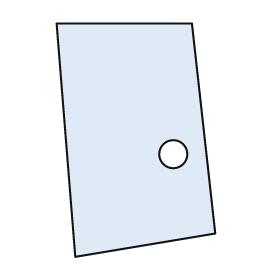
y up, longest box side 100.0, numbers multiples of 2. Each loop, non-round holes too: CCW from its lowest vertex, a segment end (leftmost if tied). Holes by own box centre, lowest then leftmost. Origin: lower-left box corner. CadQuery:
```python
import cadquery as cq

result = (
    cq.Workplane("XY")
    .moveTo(8.0, 0.0)
    .lineTo(68.0, 10.0)
    .lineTo(58.0, 100.0)
    .lineTo(0.0, 100.0)
    .close()
    .moveTo(50.0, 44.0)
    .circle(6.0)
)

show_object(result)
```